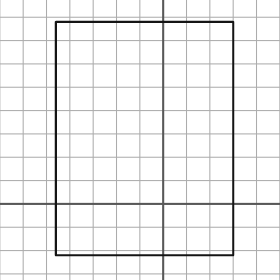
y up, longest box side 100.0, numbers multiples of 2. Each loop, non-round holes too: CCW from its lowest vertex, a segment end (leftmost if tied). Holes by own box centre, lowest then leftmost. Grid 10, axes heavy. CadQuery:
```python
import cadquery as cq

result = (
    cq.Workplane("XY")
    .moveTo(-46.0, -22.0)
    .lineTo(30.0, -22.0)
    .lineTo(30.0, 78.0)
    .lineTo(-46.0, 78.0)
    .close()
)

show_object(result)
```